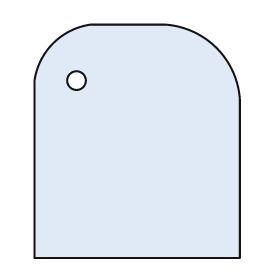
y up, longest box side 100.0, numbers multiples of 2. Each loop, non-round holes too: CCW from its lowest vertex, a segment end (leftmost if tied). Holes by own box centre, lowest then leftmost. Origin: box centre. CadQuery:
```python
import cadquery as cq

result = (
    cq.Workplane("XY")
    .moveTo(-44.0, -50.0)
    .lineTo(44.0, -50.0)
    .lineTo(44.0, 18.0)
    .threePointArc((34.0, 40.0), (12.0, 50.0))
    .lineTo(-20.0, 50.0)
    .threePointArc((-36.0, 42.0), (-44.0, 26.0))
    .close()
    .moveTo(-26.0, 26.0)
    .circle(4.0)
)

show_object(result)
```